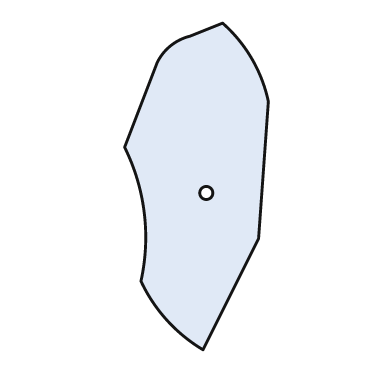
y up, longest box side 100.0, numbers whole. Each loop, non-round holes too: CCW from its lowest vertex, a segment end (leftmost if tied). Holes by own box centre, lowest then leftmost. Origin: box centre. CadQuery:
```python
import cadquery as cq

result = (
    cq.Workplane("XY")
    .moveTo(2.0, -50.0)
    .lineTo(19.0, -16.0)
    .lineTo(22.0, 26.0)
    .threePointArc((17.0, 39.0), (8.0, 50.0))
    .lineTo(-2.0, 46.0)
    .threePointArc((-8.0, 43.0), (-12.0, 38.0))
    .lineTo(-22.0, 12.0)
    .threePointArc((-16.0, -8.0), (-17.0, -29.0))
    .threePointArc((-9.0, -41.0), (2.0, -50.0))
    .close()
    .moveTo(3.0, -2.0)
    .circle(2.0)
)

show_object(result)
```